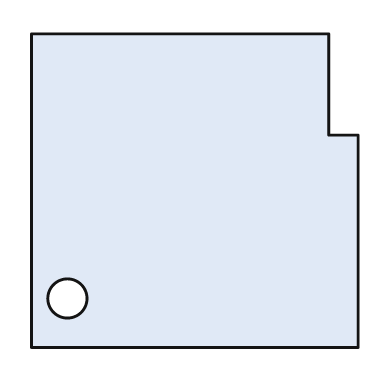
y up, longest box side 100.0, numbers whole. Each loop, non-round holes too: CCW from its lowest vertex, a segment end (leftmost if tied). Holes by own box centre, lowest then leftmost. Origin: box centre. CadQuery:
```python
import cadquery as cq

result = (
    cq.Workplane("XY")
    .moveTo(-50.0, -48.0)
    .lineTo(50.0, -48.0)
    .lineTo(50.0, 17.0)
    .lineTo(41.0, 17.0)
    .lineTo(41.0, 48.0)
    .lineTo(-50.0, 48.0)
    .close()
    .moveTo(-39.0, -33.0)
    .circle(6.0)
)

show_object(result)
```